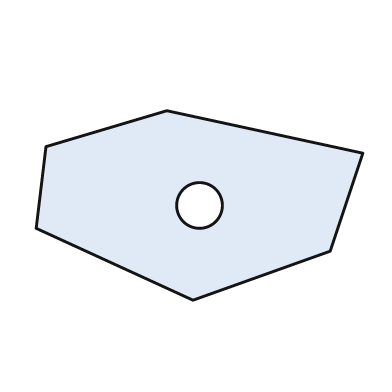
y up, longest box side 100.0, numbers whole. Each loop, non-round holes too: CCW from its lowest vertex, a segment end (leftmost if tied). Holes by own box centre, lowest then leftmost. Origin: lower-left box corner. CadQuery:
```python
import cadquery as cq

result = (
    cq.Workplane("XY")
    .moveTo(48.0, 0.0)
    .lineTo(90.0, 15.0)
    .lineTo(100.0, 45.0)
    .lineTo(40.0, 58.0)
    .lineTo(3.0, 47.0)
    .lineTo(0.0, 22.0)
    .close()
    .moveTo(50.0, 29.0)
    .circle(7.0)
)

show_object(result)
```